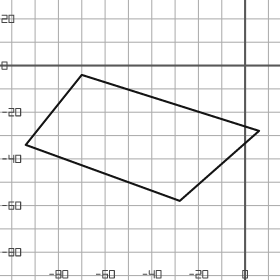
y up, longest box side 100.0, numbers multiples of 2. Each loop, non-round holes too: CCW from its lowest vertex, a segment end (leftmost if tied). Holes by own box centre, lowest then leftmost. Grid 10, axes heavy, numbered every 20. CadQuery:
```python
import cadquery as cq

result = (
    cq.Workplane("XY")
    .moveTo(-28.0, -58.0)
    .lineTo(6.0, -28.0)
    .lineTo(-70.0, -4.0)
    .lineTo(-94.0, -34.0)
    .close()
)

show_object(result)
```